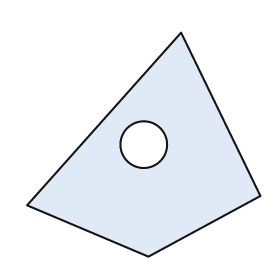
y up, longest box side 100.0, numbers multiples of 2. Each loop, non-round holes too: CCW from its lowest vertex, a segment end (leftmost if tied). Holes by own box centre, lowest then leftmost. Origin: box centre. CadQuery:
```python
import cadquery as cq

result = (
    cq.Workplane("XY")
    .moveTo(2.0, -48.0)
    .lineTo(50.0, -22.0)
    .lineTo(16.0, 48.0)
    .lineTo(-50.0, -26.0)
    .close()
    .moveTo(0.0, 0.0)
    .circle(10.0)
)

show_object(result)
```